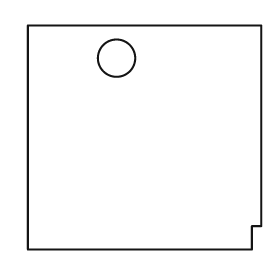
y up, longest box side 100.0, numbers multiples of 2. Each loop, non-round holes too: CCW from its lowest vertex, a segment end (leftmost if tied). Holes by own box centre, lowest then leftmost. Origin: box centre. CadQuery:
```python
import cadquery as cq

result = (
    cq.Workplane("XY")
    .moveTo(-50.0, -48.0)
    .lineTo(46.0, -48.0)
    .lineTo(46.0, -38.0)
    .lineTo(50.0, -38.0)
    .lineTo(50.0, 48.0)
    .lineTo(-50.0, 48.0)
    .close()
    .moveTo(-12.0, 34.0)
    .circle(8.0)
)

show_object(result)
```